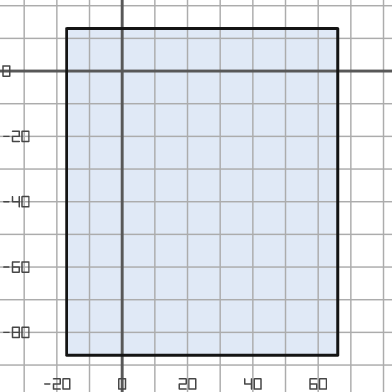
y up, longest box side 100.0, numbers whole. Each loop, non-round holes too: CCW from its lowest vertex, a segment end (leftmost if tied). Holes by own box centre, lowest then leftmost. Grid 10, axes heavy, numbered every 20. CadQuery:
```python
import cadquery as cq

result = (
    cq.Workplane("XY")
    .moveTo(-17.0, -87.0)
    .lineTo(66.0, -87.0)
    .lineTo(66.0, 13.0)
    .lineTo(-17.0, 13.0)
    .close()
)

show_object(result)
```